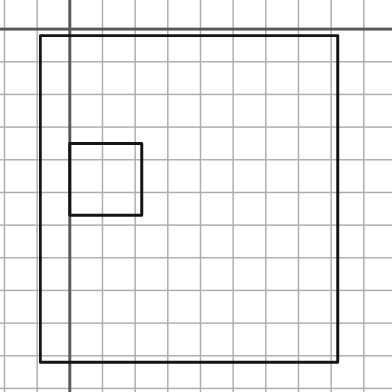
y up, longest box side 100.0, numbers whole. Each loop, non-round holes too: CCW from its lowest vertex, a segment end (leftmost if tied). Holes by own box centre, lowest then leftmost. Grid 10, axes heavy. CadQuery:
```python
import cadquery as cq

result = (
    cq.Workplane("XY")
    .moveTo(-9.0, -102.0)
    .lineTo(82.0, -102.0)
    .lineTo(82.0, -2.0)
    .lineTo(-9.0, -2.0)
    .close()
    .moveTo(0.0, -57.0)
    .lineTo(22.0, -57.0)
    .lineTo(22.0, -35.0)
    .lineTo(0.0, -35.0)
    .close()
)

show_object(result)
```